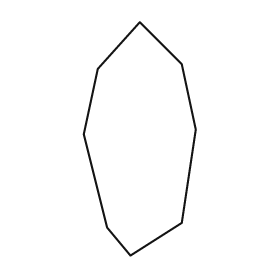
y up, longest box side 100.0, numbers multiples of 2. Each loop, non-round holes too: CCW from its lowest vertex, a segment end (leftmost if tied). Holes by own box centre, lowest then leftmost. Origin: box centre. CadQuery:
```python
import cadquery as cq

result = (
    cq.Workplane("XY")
    .moveTo(-4.0, -50.0)
    .lineTo(18.0, -36.0)
    .lineTo(24.0, 4.0)
    .lineTo(18.0, 32.0)
    .lineTo(0.0, 50.0)
    .lineTo(-18.0, 30.0)
    .lineTo(-24.0, 2.0)
    .lineTo(-14.0, -38.0)
    .close()
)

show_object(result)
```